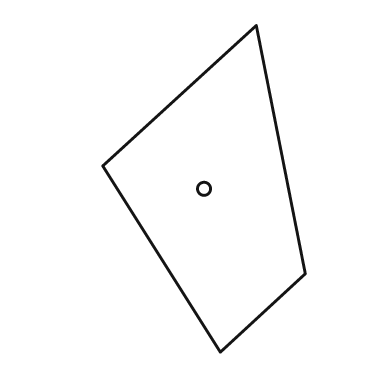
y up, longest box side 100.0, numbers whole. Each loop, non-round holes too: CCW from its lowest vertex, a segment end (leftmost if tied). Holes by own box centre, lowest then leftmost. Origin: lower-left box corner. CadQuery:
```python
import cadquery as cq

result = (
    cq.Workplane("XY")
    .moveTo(36.0, 0.0)
    .lineTo(62.0, 24.0)
    .lineTo(47.0, 100.0)
    .lineTo(0.0, 57.0)
    .close()
    .moveTo(31.0, 50.0)
    .circle(2.0)
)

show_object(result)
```